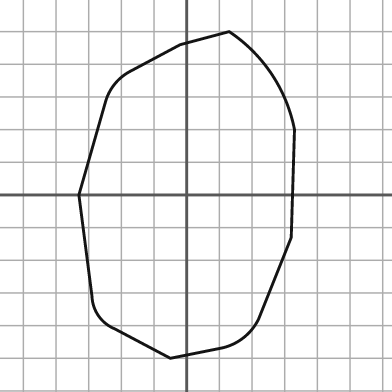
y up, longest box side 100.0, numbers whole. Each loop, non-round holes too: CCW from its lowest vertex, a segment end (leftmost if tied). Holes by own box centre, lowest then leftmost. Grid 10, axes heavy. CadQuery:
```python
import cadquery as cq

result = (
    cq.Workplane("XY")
    .moveTo(-5.0, -50.0)
    .lineTo(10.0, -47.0)
    .threePointArc((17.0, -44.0), (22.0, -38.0))
    .lineTo(32.0, -13.0)
    .lineTo(33.0, 20.0)
    .threePointArc((26.0, 37.0), (13.0, 50.0))
    .lineTo(-2.0, 46.0)
    .lineTo(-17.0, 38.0)
    .threePointArc((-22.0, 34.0), (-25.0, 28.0))
    .lineTo(-33.0, 0.0)
    .lineTo(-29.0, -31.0)
    .threePointArc((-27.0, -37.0), (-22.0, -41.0))
    .close()
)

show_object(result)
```